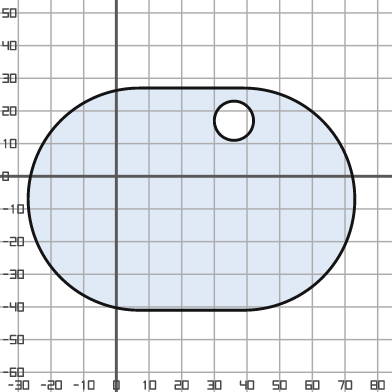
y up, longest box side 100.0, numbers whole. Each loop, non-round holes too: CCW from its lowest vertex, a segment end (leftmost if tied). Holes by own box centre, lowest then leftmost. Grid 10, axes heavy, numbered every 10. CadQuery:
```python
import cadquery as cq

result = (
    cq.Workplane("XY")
    .moveTo(7.0, -41.0)
    .lineTo(39.0, -41.0)
    .threePointArc((73.0, -7.0), (39.0, 27.0))
    .lineTo(7.0, 27.0)
    .threePointArc((-27.0, -7.0), (7.0, -41.0))
    .close()
    .moveTo(36.0, 17.0)
    .circle(6.0)
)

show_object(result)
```